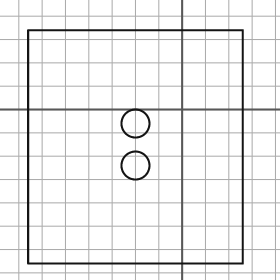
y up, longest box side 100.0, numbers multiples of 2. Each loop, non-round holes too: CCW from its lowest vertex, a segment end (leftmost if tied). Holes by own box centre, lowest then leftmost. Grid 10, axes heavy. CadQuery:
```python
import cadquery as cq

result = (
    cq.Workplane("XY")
    .moveTo(-66.0, -66.0)
    .lineTo(26.0, -66.0)
    .lineTo(26.0, 34.0)
    .lineTo(-66.0, 34.0)
    .close()
    .moveTo(-20.0, -24.0)
    .circle(6.0)
    .moveTo(-20.0, -6.0)
    .circle(6.0)
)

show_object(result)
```